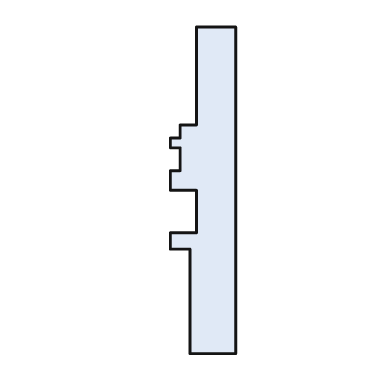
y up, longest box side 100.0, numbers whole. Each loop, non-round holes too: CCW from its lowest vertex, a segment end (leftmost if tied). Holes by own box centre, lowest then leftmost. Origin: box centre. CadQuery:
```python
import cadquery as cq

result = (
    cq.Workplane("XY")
    .moveTo(-4.0, -50.0)
    .lineTo(10.0, -50.0)
    .lineTo(10.0, 50.0)
    .lineTo(-2.0, 50.0)
    .lineTo(-2.0, 20.0)
    .lineTo(-7.0, 20.0)
    .lineTo(-7.0, 16.0)
    .lineTo(-10.0, 16.0)
    .lineTo(-10.0, 13.0)
    .lineTo(-7.0, 13.0)
    .lineTo(-7.0, 6.0)
    .lineTo(-10.0, 6.0)
    .lineTo(-10.0, 0.0)
    .lineTo(-2.0, 0.0)
    .lineTo(-2.0, -13.0)
    .lineTo(-10.0, -13.0)
    .lineTo(-10.0, -18.0)
    .lineTo(-4.0, -18.0)
    .close()
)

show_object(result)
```